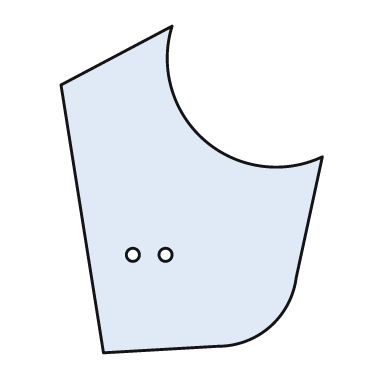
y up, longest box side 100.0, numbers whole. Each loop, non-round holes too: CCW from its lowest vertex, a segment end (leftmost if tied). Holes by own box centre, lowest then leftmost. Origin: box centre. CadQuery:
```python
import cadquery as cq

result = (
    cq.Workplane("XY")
    .moveTo(-27.0, -50.0)
    .lineTo(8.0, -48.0)
    .threePointArc((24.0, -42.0), (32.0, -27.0))
    .lineTo(40.0, 10.0)
    .threePointArc((4.0, 15.0), (-6.0, 50.0))
    .lineTo(-40.0, 32.0)
    .close()
    .moveTo(-18.0, -20.0)
    .circle(2.0)
    .moveTo(-8.0, -20.0)
    .circle(2.0)
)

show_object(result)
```